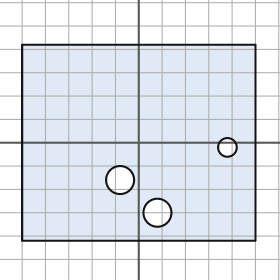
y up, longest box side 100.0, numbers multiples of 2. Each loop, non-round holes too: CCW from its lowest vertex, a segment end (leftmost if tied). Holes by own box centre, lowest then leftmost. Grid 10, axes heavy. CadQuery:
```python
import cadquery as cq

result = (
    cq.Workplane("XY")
    .moveTo(-50.0, -42.0)
    .lineTo(50.0, -42.0)
    .lineTo(50.0, 42.0)
    .lineTo(-50.0, 42.0)
    .close()
    .moveTo(8.0, -30.0)
    .circle(6.0)
    .moveTo(-8.0, -16.0)
    .circle(6.0)
    .moveTo(38.0, -2.0)
    .circle(4.0)
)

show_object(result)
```